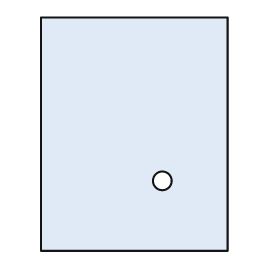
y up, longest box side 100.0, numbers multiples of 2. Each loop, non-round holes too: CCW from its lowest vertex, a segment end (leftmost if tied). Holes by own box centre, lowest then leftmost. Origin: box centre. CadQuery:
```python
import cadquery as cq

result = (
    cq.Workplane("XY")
    .moveTo(-40.0, -50.0)
    .lineTo(40.0, -50.0)
    .lineTo(40.0, 50.0)
    .lineTo(-40.0, 50.0)
    .close()
    .moveTo(12.0, -20.0)
    .circle(4.0)
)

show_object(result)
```